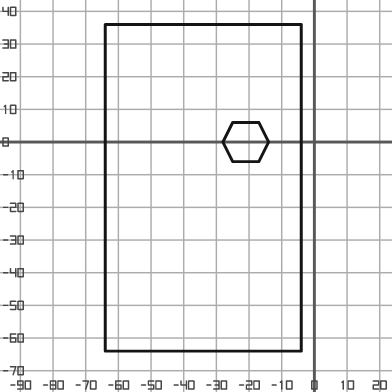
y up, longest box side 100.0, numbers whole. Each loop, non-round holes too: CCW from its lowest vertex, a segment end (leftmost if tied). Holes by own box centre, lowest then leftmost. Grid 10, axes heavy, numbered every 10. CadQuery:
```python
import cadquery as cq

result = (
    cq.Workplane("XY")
    .moveTo(-64.0, -64.0)
    .lineTo(-4.0, -64.0)
    .lineTo(-4.0, 36.0)
    .lineTo(-64.0, 36.0)
    .close()
    .moveTo(-25.0, -6.0)
    .lineTo(-17.0, -6.0)
    .lineTo(-14.0, 0.0)
    .lineTo(-17.0, 6.0)
    .lineTo(-25.0, 6.0)
    .lineTo(-28.0, 0.0)
    .close()
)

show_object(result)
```